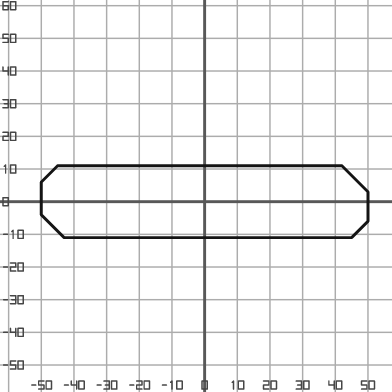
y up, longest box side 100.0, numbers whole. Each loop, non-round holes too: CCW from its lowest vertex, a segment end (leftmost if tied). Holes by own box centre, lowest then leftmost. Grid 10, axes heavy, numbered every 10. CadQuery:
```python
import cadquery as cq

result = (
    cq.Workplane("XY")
    .moveTo(-43.0, -11.0)
    .lineTo(45.0, -11.0)
    .lineTo(50.0, -6.0)
    .lineTo(50.0, 3.0)
    .lineTo(42.0, 11.0)
    .lineTo(-45.0, 11.0)
    .lineTo(-50.0, 6.0)
    .lineTo(-50.0, -4.0)
    .close()
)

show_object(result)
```